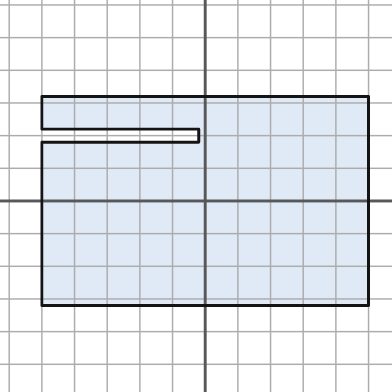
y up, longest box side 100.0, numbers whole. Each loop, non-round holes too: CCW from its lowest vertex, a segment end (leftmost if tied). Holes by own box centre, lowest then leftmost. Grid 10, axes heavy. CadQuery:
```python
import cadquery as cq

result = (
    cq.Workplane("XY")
    .moveTo(-50.0, -32.0)
    .lineTo(50.0, -32.0)
    .lineTo(50.0, 32.0)
    .lineTo(-50.0, 32.0)
    .lineTo(-50.0, 22.0)
    .lineTo(-2.0, 22.0)
    .lineTo(-2.0, 18.0)
    .lineTo(-50.0, 18.0)
    .close()
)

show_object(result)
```